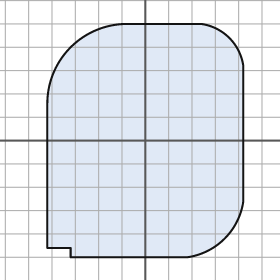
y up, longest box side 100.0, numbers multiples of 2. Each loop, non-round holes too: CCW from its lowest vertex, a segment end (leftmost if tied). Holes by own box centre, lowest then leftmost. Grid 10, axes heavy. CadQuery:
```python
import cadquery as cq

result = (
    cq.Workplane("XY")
    .moveTo(-32.0, -50.0)
    .lineTo(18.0, -50.0)
    .threePointArc((34.0, -42.0), (42.0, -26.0))
    .lineTo(42.0, 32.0)
    .threePointArc((36.0, 44.0), (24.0, 50.0))
    .lineTo(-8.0, 50.0)
    .threePointArc((-32.0, 40.0), (-42.0, 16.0))
    .lineTo(-42.0, -46.0)
    .lineTo(-32.0, -46.0)
    .close()
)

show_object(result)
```